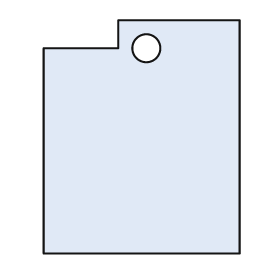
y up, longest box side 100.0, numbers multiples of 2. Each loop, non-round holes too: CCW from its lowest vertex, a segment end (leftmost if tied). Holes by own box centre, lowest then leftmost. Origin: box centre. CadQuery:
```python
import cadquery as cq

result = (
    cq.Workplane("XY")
    .moveTo(-42.0, -50.0)
    .lineTo(42.0, -50.0)
    .lineTo(42.0, 50.0)
    .lineTo(-10.0, 50.0)
    .lineTo(-10.0, 38.0)
    .lineTo(-42.0, 38.0)
    .close()
    .moveTo(2.0, 38.0)
    .circle(6.0)
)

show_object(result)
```